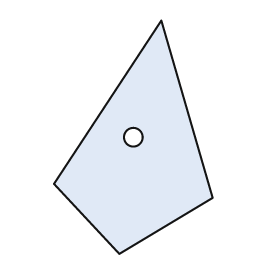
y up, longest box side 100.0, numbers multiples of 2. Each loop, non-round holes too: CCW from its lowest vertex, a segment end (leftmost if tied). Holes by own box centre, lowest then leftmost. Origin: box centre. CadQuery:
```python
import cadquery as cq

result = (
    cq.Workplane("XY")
    .moveTo(-6.0, -50.0)
    .lineTo(34.0, -26.0)
    .lineTo(12.0, 50.0)
    .lineTo(-34.0, -20.0)
    .close()
    .moveTo(0.0, 0.0)
    .circle(4.0)
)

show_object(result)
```